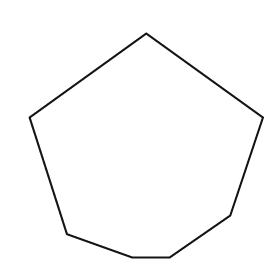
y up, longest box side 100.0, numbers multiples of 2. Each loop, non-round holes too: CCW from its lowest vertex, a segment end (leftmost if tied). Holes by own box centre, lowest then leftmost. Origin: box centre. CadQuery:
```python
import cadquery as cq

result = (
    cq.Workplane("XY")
    .moveTo(-6.0, -48.0)
    .lineTo(10.0, -48.0)
    .lineTo(36.0, -30.0)
    .lineTo(50.0, 12.0)
    .lineTo(0.0, 48.0)
    .lineTo(-50.0, 12.0)
    .lineTo(-34.0, -38.0)
    .close()
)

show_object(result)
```